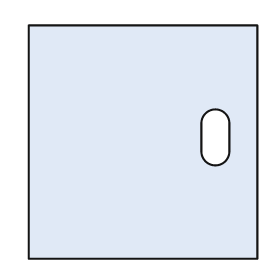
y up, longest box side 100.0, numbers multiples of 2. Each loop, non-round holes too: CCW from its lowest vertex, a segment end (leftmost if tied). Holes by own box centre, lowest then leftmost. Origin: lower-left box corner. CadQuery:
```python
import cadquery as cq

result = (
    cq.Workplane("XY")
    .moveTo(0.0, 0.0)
    .lineTo(98.0, 0.0)
    .lineTo(98.0, 100.0)
    .lineTo(0.0, 100.0)
    .close()
    .moveTo(74.0, 46.0)
    .threePointArc((80.0, 40.0), (86.0, 46.0))
    .lineTo(86.0, 58.0)
    .threePointArc((80.0, 64.0), (74.0, 58.0))
    .close()
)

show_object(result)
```